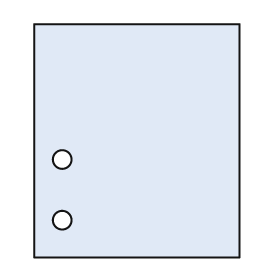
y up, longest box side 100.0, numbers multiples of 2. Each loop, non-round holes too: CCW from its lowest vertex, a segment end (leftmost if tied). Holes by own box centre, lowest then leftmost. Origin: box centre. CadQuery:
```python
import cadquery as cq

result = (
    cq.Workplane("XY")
    .moveTo(-44.0, -50.0)
    .lineTo(44.0, -50.0)
    .lineTo(44.0, 50.0)
    .lineTo(-44.0, 50.0)
    .close()
    .moveTo(-32.0, -34.0)
    .circle(4.0)
    .moveTo(-32.0, -8.0)
    .circle(4.0)
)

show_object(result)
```